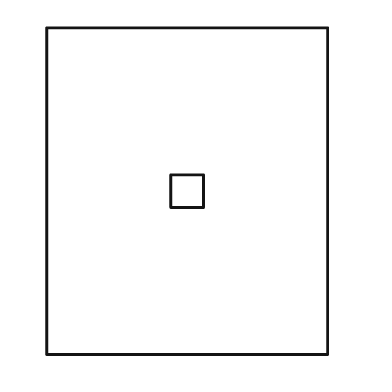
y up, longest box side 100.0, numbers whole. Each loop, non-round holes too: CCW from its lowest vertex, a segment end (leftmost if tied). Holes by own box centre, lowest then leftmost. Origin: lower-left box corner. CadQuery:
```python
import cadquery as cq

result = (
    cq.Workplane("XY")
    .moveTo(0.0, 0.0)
    .lineTo(86.0, 0.0)
    .lineTo(86.0, 100.0)
    .lineTo(0.0, 100.0)
    .close()
    .moveTo(38.0, 45.0)
    .lineTo(48.0, 45.0)
    .lineTo(48.0, 55.0)
    .lineTo(38.0, 55.0)
    .close()
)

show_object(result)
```